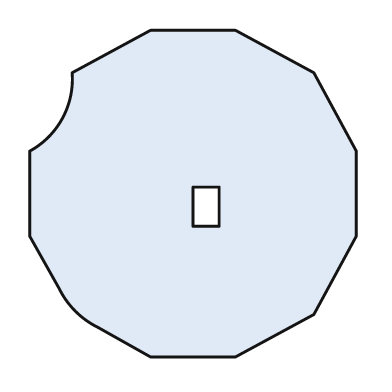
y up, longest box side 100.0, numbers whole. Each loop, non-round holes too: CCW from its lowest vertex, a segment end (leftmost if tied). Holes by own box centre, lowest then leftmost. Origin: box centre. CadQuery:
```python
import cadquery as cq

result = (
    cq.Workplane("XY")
    .moveTo(-13.0, -50.0)
    .lineTo(13.0, -50.0)
    .lineTo(37.0, -37.0)
    .lineTo(50.0, -13.0)
    .lineTo(50.0, 13.0)
    .lineTo(37.0, 37.0)
    .lineTo(13.0, 50.0)
    .lineTo(-13.0, 50.0)
    .lineTo(-37.0, 37.0)
    .threePointArc((-40.0, 23.0), (-50.0, 13.0))
    .lineTo(-50.0, -13.0)
    .lineTo(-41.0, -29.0)
    .threePointArc((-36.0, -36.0), (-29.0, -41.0))
    .close()
    .moveTo(0.0, -10.0)
    .lineTo(8.0, -10.0)
    .lineTo(8.0, 2.0)
    .lineTo(0.0, 2.0)
    .close()
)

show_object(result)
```